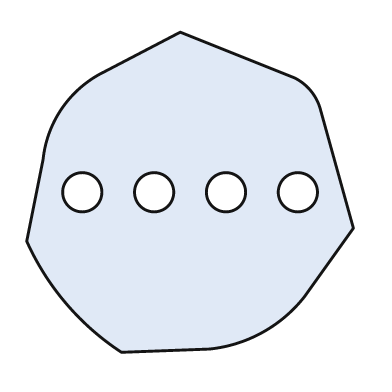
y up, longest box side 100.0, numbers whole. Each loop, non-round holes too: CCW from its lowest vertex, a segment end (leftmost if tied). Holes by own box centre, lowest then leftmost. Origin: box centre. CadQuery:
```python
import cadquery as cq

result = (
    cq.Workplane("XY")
    .moveTo(-21.0, -49.0)
    .lineTo(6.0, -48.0)
    .threePointArc((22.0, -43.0), (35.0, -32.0))
    .lineTo(50.0, -11.0)
    .lineTo(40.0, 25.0)
    .threePointArc((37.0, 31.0), (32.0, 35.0))
    .lineTo(-3.0, 49.0)
    .lineTo(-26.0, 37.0)
    .threePointArc((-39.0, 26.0), (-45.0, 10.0))
    .lineTo(-50.0, -15.0)
    .threePointArc((-38.0, -34.0), (-21.0, -49.0))
    .close()
    .moveTo(-33.0, 0.0)
    .circle(6.0)
    .moveTo(-11.0, 0.0)
    .circle(6.0)
    .moveTo(11.0, 0.0)
    .circle(6.0)
    .moveTo(33.0, 0.0)
    .circle(6.0)
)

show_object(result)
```